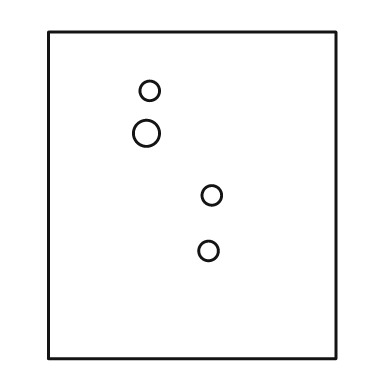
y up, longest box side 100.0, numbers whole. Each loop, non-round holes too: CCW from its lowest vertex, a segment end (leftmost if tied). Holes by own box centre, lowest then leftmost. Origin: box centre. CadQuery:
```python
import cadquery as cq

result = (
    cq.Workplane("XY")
    .moveTo(-44.0, -50.0)
    .lineTo(44.0, -50.0)
    .lineTo(44.0, 50.0)
    .lineTo(-44.0, 50.0)
    .close()
    .moveTo(5.0, -17.0)
    .circle(3.0)
    .moveTo(6.0, 0.0)
    .circle(3.0)
    .moveTo(-14.0, 19.0)
    .circle(4.0)
    .moveTo(-13.0, 32.0)
    .circle(3.0)
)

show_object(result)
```